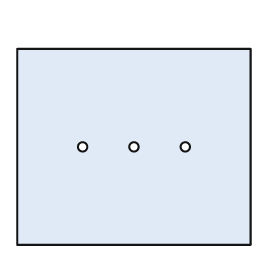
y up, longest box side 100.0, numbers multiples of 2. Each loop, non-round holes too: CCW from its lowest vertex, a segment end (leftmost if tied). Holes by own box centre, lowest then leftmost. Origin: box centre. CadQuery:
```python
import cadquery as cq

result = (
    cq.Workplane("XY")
    .moveTo(-50.0, -42.0)
    .lineTo(50.0, -42.0)
    .lineTo(50.0, 42.0)
    .lineTo(-50.0, 42.0)
    .close()
    .moveTo(-22.0, 0.0)
    .circle(2.0)
    .moveTo(0.0, 0.0)
    .circle(2.0)
    .moveTo(22.0, 0.0)
    .circle(2.0)
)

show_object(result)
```